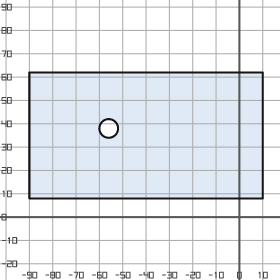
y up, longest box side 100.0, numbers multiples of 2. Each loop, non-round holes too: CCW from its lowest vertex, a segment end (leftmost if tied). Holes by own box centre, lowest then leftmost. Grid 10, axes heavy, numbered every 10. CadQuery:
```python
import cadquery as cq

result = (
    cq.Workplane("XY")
    .moveTo(-90.0, 8.0)
    .lineTo(10.0, 8.0)
    .lineTo(10.0, 62.0)
    .lineTo(-90.0, 62.0)
    .close()
    .moveTo(-56.0, 38.0)
    .circle(4.0)
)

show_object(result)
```